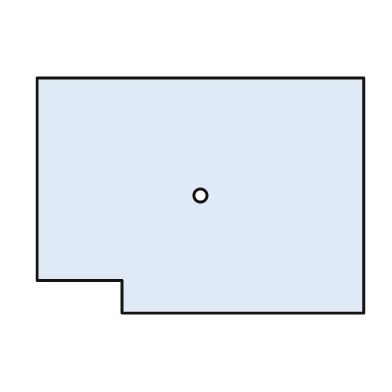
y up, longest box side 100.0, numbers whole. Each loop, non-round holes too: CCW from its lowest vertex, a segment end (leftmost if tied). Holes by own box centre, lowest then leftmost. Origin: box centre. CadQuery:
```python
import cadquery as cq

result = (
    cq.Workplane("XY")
    .moveTo(-24.0, -36.0)
    .lineTo(50.0, -36.0)
    .lineTo(50.0, 36.0)
    .lineTo(-50.0, 36.0)
    .lineTo(-50.0, -26.0)
    .lineTo(-24.0, -26.0)
    .close()
    .moveTo(0.0, 0.0)
    .circle(2.0)
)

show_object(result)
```